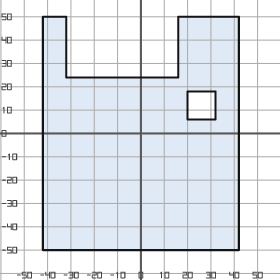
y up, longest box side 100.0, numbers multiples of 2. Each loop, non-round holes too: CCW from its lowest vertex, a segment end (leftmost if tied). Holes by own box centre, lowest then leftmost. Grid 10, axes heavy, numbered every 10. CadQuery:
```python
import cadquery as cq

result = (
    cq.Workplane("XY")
    .moveTo(-42.0, -50.0)
    .lineTo(42.0, -50.0)
    .lineTo(42.0, 50.0)
    .lineTo(16.0, 50.0)
    .lineTo(16.0, 24.0)
    .lineTo(-32.0, 24.0)
    .lineTo(-32.0, 50.0)
    .lineTo(-42.0, 50.0)
    .close()
    .moveTo(20.0, 6.0)
    .lineTo(32.0, 6.0)
    .lineTo(32.0, 18.0)
    .lineTo(20.0, 18.0)
    .close()
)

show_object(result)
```